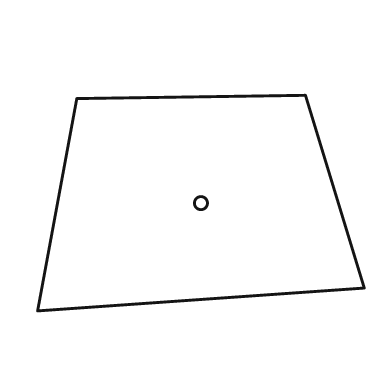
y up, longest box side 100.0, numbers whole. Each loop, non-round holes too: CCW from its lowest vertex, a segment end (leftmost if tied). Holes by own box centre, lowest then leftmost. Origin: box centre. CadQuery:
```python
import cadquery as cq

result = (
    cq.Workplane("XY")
    .moveTo(-50.0, -33.0)
    .lineTo(50.0, -26.0)
    .lineTo(32.0, 33.0)
    .lineTo(-38.0, 32.0)
    .close()
    .moveTo(0.0, 0.0)
    .circle(2.0)
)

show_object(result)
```